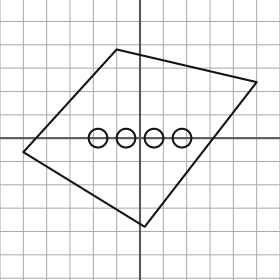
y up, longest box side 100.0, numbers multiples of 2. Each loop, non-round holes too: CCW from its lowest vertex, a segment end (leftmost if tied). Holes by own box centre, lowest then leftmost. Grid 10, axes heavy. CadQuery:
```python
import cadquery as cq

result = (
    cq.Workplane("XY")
    .moveTo(2.0, -38.0)
    .lineTo(50.0, 24.0)
    .lineTo(-10.0, 38.0)
    .lineTo(-50.0, -6.0)
    .close()
    .moveTo(-18.0, 0.0)
    .circle(4.0)
    .moveTo(-6.0, 0.0)
    .circle(4.0)
    .moveTo(6.0, 0.0)
    .circle(4.0)
    .moveTo(18.0, 0.0)
    .circle(4.0)
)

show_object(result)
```